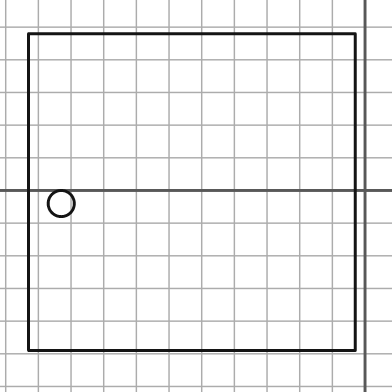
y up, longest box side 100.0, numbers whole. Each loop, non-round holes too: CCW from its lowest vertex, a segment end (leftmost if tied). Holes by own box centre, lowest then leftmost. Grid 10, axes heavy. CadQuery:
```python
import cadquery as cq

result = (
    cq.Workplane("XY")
    .moveTo(-103.0, -49.0)
    .lineTo(-3.0, -49.0)
    .lineTo(-3.0, 48.0)
    .lineTo(-103.0, 48.0)
    .close()
    .moveTo(-93.0, -4.0)
    .circle(4.0)
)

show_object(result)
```